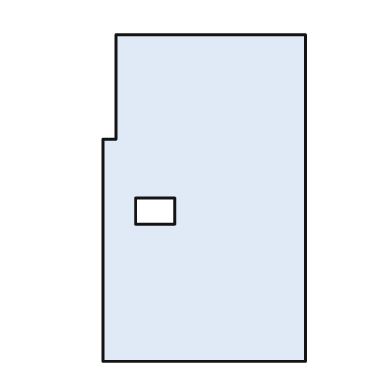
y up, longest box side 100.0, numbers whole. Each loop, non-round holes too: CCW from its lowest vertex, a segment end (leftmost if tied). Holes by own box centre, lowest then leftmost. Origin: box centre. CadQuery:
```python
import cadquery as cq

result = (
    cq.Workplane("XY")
    .moveTo(-31.0, -50.0)
    .lineTo(31.0, -50.0)
    .lineTo(31.0, 50.0)
    .lineTo(-27.0, 50.0)
    .lineTo(-27.0, 18.0)
    .lineTo(-31.0, 18.0)
    .close()
    .moveTo(-21.0, -8.0)
    .lineTo(-9.0, -8.0)
    .lineTo(-9.0, 0.0)
    .lineTo(-21.0, 0.0)
    .close()
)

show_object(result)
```